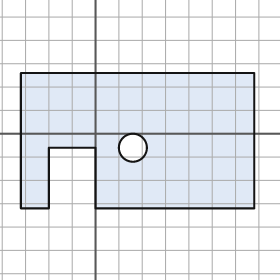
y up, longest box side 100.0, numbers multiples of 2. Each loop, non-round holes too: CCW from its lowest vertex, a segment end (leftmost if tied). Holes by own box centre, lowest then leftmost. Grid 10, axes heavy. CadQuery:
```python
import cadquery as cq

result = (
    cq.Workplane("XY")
    .moveTo(-32.0, -32.0)
    .lineTo(-20.0, -32.0)
    .lineTo(-20.0, -6.0)
    .lineTo(0.0, -6.0)
    .lineTo(0.0, -32.0)
    .lineTo(68.0, -32.0)
    .lineTo(68.0, 26.0)
    .lineTo(-32.0, 26.0)
    .close()
    .moveTo(16.0, -6.0)
    .circle(6.0)
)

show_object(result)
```